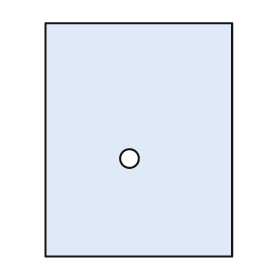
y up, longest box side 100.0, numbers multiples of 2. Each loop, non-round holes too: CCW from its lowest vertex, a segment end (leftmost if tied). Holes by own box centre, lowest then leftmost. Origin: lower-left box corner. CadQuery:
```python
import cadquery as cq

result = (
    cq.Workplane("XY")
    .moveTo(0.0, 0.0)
    .lineTo(80.0, 0.0)
    .lineTo(80.0, 100.0)
    .lineTo(0.0, 100.0)
    .close()
    .moveTo(36.0, 42.0)
    .circle(4.0)
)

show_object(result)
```